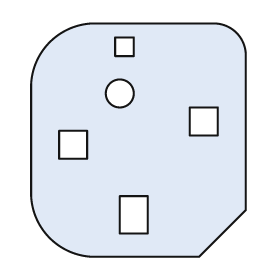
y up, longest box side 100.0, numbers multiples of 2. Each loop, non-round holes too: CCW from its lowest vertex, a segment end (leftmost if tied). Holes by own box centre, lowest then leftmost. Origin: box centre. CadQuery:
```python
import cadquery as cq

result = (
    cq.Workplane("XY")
    .moveTo(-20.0, -50.0)
    .lineTo(26.0, -50.0)
    .lineTo(46.0, -30.0)
    .lineTo(46.0, 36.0)
    .threePointArc((42.0, 46.0), (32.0, 50.0))
    .lineTo(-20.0, 50.0)
    .threePointArc((-38.0, 42.0), (-46.0, 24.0))
    .lineTo(-46.0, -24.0)
    .threePointArc((-38.0, -42.0), (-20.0, -50.0))
    .close()
    .moveTo(-8.0, -40.0)
    .lineTo(4.0, -40.0)
    .lineTo(4.0, -24.0)
    .lineTo(-8.0, -24.0)
    .close()
    .moveTo(-34.0, -8.0)
    .lineTo(-22.0, -8.0)
    .lineTo(-22.0, 4.0)
    .lineTo(-34.0, 4.0)
    .close()
    .moveTo(22.0, 2.0)
    .lineTo(34.0, 2.0)
    .lineTo(34.0, 14.0)
    .lineTo(22.0, 14.0)
    .close()
    .moveTo(-8.0, 20.0)
    .circle(6.0)
    .moveTo(-10.0, 36.0)
    .lineTo(-2.0, 36.0)
    .lineTo(-2.0, 44.0)
    .lineTo(-10.0, 44.0)
    .close()
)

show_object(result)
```